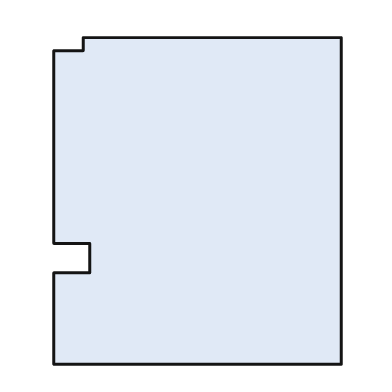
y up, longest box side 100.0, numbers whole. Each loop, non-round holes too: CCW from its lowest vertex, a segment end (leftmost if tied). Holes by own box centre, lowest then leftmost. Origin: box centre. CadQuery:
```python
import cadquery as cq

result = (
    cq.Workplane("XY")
    .moveTo(-44.0, -50.0)
    .lineTo(44.0, -50.0)
    .lineTo(44.0, 50.0)
    .lineTo(-35.0, 50.0)
    .lineTo(-35.0, 46.0)
    .lineTo(-44.0, 46.0)
    .lineTo(-44.0, -13.0)
    .lineTo(-33.0, -13.0)
    .lineTo(-33.0, -22.0)
    .lineTo(-44.0, -22.0)
    .close()
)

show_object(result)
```